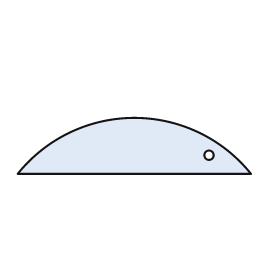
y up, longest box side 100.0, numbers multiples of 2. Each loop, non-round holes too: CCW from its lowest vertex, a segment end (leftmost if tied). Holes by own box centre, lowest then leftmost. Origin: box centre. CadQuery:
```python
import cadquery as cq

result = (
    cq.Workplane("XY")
    .moveTo(-50.0, -12.0)
    .lineTo(50.0, -12.0)
    .threePointArc((0.0, 12.0), (-50.0, -12.0))
    .close()
    .moveTo(32.0, -4.0)
    .circle(2.0)
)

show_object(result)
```